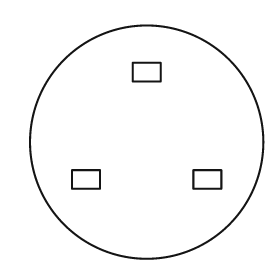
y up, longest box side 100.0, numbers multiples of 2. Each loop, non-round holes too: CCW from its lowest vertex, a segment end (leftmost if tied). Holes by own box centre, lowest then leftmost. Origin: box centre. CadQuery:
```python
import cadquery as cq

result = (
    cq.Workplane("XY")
    .moveTo(0.0, 0.0)
    .circle(50.0)
    .moveTo(-32.0, -20.0)
    .lineTo(-20.0, -20.0)
    .lineTo(-20.0, -12.0)
    .lineTo(-32.0, -12.0)
    .close()
    .moveTo(20.0, -20.0)
    .lineTo(32.0, -20.0)
    .lineTo(32.0, -12.0)
    .lineTo(20.0, -12.0)
    .close()
    .moveTo(-6.0, 26.0)
    .lineTo(6.0, 26.0)
    .lineTo(6.0, 34.0)
    .lineTo(-6.0, 34.0)
    .close()
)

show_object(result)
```